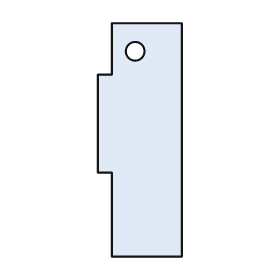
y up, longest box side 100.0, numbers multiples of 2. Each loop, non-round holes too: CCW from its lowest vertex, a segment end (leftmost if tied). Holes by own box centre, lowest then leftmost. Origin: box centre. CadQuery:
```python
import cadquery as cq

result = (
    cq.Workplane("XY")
    .moveTo(-12.0, -50.0)
    .lineTo(18.0, -50.0)
    .lineTo(18.0, 50.0)
    .lineTo(-12.0, 50.0)
    .lineTo(-12.0, 28.0)
    .lineTo(-18.0, 28.0)
    .lineTo(-18.0, -14.0)
    .lineTo(-12.0, -14.0)
    .close()
    .moveTo(-2.0, 38.0)
    .circle(4.0)
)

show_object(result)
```